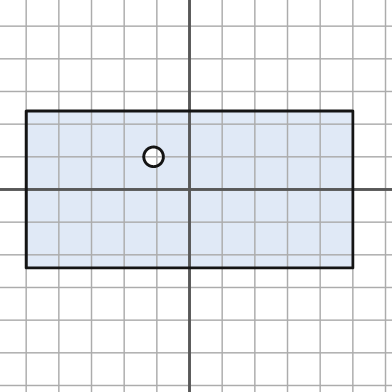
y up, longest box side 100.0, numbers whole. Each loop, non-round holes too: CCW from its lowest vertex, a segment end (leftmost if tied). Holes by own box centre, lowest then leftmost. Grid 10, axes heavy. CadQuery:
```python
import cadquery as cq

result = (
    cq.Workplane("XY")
    .moveTo(-50.0, -24.0)
    .lineTo(50.0, -24.0)
    .lineTo(50.0, 24.0)
    .lineTo(-50.0, 24.0)
    .close()
    .moveTo(-11.0, 10.0)
    .circle(3.0)
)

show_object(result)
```